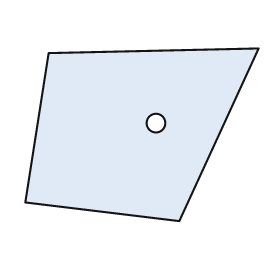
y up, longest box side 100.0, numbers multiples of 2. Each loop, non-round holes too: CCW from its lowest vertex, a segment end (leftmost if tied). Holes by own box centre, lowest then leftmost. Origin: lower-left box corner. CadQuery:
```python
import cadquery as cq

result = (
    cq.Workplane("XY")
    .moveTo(66.0, 0.0)
    .lineTo(100.0, 74.0)
    .lineTo(10.0, 72.0)
    .lineTo(0.0, 8.0)
    .close()
    .moveTo(56.0, 42.0)
    .circle(4.0)
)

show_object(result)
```